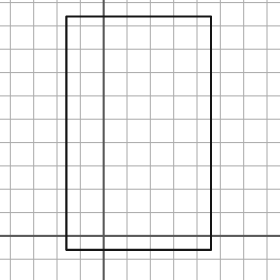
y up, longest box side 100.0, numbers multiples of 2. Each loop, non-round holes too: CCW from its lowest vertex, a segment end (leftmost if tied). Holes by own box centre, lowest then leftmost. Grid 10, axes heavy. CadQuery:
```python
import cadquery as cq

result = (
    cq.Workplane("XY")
    .moveTo(-16.0, -6.0)
    .lineTo(46.0, -6.0)
    .lineTo(46.0, 94.0)
    .lineTo(-16.0, 94.0)
    .close()
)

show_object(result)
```